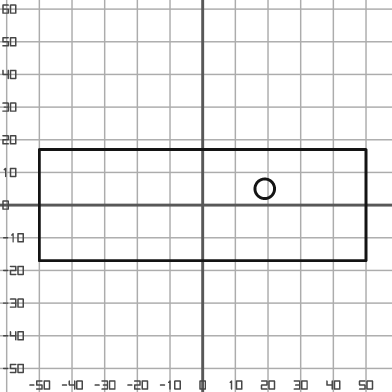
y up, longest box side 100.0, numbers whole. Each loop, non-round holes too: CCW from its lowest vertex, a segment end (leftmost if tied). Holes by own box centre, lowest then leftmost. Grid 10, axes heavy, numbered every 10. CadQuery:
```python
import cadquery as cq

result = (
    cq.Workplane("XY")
    .moveTo(-50.0, -17.0)
    .lineTo(50.0, -17.0)
    .lineTo(50.0, 17.0)
    .lineTo(-50.0, 17.0)
    .close()
    .moveTo(19.0, 5.0)
    .circle(3.0)
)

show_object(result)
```